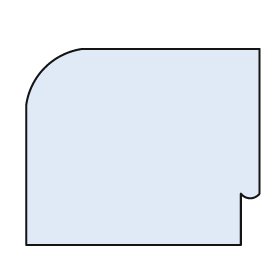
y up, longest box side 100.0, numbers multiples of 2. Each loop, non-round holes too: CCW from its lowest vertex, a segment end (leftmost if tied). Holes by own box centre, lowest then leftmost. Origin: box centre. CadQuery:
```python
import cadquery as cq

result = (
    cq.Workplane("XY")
    .moveTo(-50.0, -42.0)
    .lineTo(42.0, -42.0)
    .lineTo(42.0, -20.0)
    .threePointArc((46.0, -22.0), (50.0, -20.0))
    .lineTo(50.0, 42.0)
    .lineTo(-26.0, 42.0)
    .threePointArc((-42.0, 34.0), (-50.0, 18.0))
    .close()
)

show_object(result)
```